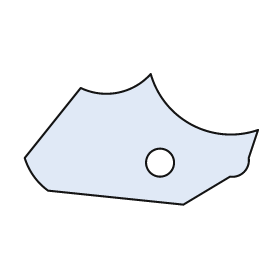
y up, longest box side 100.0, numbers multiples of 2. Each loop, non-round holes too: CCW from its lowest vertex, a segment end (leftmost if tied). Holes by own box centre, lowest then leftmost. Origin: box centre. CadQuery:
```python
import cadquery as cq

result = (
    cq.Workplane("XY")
    .moveTo(18.0, -28.0)
    .lineTo(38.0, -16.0)
    .threePointArc((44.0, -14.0), (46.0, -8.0))
    .lineTo(50.0, 4.0)
    .threePointArc((22.0, 6.0), (4.0, 28.0))
    .threePointArc((-10.0, 20.0), (-26.0, 22.0))
    .lineTo(-50.0, -8.0)
    .threePointArc((-46.0, -16.0), (-40.0, -22.0))
    .close()
    .moveTo(8.0, -10.0)
    .circle(6.0)
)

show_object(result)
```